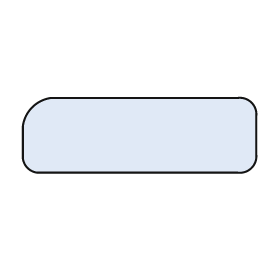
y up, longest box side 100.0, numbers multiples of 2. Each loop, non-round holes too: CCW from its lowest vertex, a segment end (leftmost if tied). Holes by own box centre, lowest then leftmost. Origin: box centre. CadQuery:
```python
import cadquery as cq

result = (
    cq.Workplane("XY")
    .moveTo(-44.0, -16.0)
    .lineTo(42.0, -16.0)
    .threePointArc((48.0, -14.0), (50.0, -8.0))
    .lineTo(50.0, 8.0)
    .threePointArc((48.0, 14.0), (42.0, 16.0))
    .lineTo(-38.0, 16.0)
    .threePointArc((-46.0, 12.0), (-50.0, 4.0))
    .lineTo(-50.0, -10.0)
    .threePointArc((-48.0, -14.0), (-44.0, -16.0))
    .close()
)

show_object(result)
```